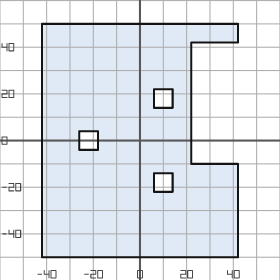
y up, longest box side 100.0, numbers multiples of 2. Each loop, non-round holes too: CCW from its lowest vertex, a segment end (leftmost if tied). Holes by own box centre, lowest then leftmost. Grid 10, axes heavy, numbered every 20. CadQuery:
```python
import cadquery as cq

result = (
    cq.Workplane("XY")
    .moveTo(-42.0, -50.0)
    .lineTo(42.0, -50.0)
    .lineTo(42.0, -10.0)
    .lineTo(22.0, -10.0)
    .lineTo(22.0, 42.0)
    .lineTo(42.0, 42.0)
    .lineTo(42.0, 50.0)
    .lineTo(-42.0, 50.0)
    .close()
    .moveTo(6.0, -22.0)
    .lineTo(14.0, -22.0)
    .lineTo(14.0, -14.0)
    .lineTo(6.0, -14.0)
    .close()
    .moveTo(-26.0, -4.0)
    .lineTo(-18.0, -4.0)
    .lineTo(-18.0, 4.0)
    .lineTo(-26.0, 4.0)
    .close()
    .moveTo(6.0, 14.0)
    .lineTo(14.0, 14.0)
    .lineTo(14.0, 22.0)
    .lineTo(6.0, 22.0)
    .close()
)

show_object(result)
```